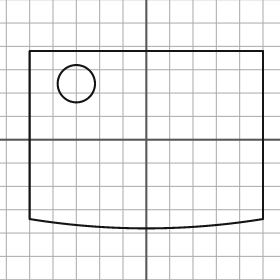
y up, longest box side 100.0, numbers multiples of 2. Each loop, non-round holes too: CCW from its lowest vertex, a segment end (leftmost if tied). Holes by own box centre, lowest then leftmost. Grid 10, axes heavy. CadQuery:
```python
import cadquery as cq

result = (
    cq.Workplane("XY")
    .moveTo(-50.0, -34.0)
    .threePointArc((0.0, -38.0), (50.0, -34.0))
    .lineTo(50.0, 38.0)
    .lineTo(-50.0, 38.0)
    .close()
    .moveTo(-30.0, 24.0)
    .circle(8.0)
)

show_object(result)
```